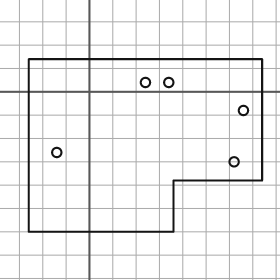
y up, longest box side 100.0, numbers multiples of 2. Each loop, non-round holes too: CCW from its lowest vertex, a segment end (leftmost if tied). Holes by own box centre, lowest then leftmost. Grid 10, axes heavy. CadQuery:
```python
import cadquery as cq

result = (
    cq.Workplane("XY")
    .moveTo(-26.0, -60.0)
    .lineTo(36.0, -60.0)
    .lineTo(36.0, -38.0)
    .lineTo(74.0, -38.0)
    .lineTo(74.0, 14.0)
    .lineTo(-26.0, 14.0)
    .close()
    .moveTo(62.0, -30.0)
    .circle(2.0)
    .moveTo(-14.0, -26.0)
    .circle(2.0)
    .moveTo(66.0, -8.0)
    .circle(2.0)
    .moveTo(24.0, 4.0)
    .circle(2.0)
    .moveTo(34.0, 4.0)
    .circle(2.0)
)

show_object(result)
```